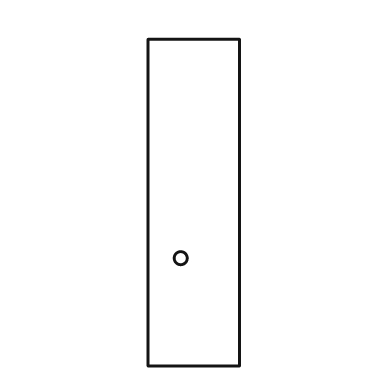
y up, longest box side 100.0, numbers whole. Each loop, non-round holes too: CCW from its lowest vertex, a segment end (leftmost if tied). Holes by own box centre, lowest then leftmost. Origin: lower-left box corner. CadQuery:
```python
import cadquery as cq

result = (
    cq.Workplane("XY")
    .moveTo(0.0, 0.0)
    .lineTo(28.0, 0.0)
    .lineTo(28.0, 100.0)
    .lineTo(0.0, 100.0)
    .close()
    .moveTo(10.0, 33.0)
    .circle(2.0)
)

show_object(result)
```